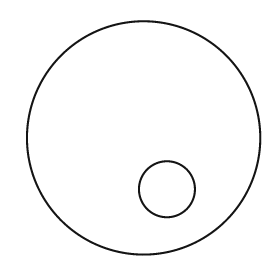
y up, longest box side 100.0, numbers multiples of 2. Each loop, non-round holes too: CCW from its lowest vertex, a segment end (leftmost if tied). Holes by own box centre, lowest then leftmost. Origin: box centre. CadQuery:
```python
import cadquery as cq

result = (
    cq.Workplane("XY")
    .moveTo(0.0, 0.0)
    .circle(50.0)
    .moveTo(10.0, -22.0)
    .circle(12.0)
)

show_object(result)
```